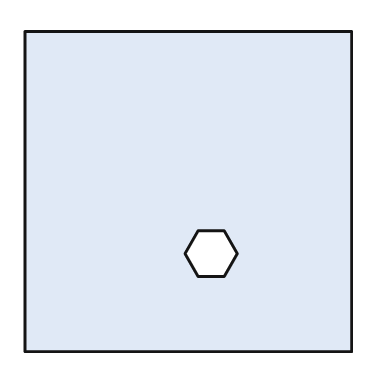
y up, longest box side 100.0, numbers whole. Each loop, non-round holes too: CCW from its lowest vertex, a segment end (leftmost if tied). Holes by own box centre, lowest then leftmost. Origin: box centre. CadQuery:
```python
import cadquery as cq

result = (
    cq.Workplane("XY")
    .moveTo(-50.0, -49.0)
    .lineTo(50.0, -49.0)
    .lineTo(50.0, 49.0)
    .lineTo(-50.0, 49.0)
    .close()
    .moveTo(3.0, -26.0)
    .lineTo(11.0, -26.0)
    .lineTo(15.0, -19.0)
    .lineTo(11.0, -12.0)
    .lineTo(3.0, -12.0)
    .lineTo(-1.0, -19.0)
    .close()
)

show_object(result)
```